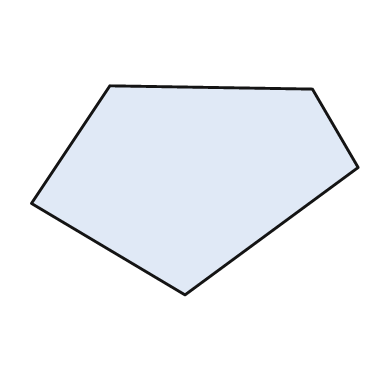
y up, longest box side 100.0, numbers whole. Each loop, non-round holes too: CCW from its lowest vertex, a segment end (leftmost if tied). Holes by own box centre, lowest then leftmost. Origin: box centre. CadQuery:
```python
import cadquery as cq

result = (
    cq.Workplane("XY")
    .moveTo(-3.0, -32.0)
    .lineTo(50.0, 7.0)
    .lineTo(36.0, 31.0)
    .lineTo(-26.0, 32.0)
    .lineTo(-50.0, -4.0)
    .close()
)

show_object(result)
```